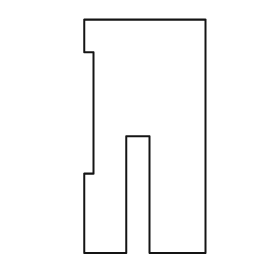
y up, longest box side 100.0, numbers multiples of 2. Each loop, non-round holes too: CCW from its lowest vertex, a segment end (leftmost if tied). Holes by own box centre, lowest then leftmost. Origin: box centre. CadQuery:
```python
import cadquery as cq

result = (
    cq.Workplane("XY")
    .moveTo(-26.0, -50.0)
    .lineTo(-8.0, -50.0)
    .lineTo(-8.0, 0.0)
    .lineTo(2.0, 0.0)
    .lineTo(2.0, -50.0)
    .lineTo(26.0, -50.0)
    .lineTo(26.0, 50.0)
    .lineTo(-26.0, 50.0)
    .lineTo(-26.0, 36.0)
    .lineTo(-22.0, 36.0)
    .lineTo(-22.0, -16.0)
    .lineTo(-26.0, -16.0)
    .close()
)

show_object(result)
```